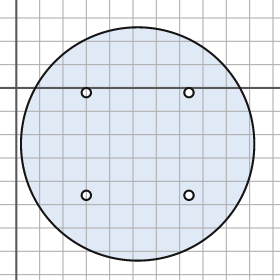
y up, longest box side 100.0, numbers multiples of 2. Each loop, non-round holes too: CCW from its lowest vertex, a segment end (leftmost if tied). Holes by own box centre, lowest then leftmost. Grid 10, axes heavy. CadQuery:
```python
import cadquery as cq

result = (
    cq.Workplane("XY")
    .moveTo(52.0, -24.0)
    .circle(50.0)
    .moveTo(30.0, -46.0)
    .circle(2.0)
    .moveTo(74.0, -46.0)
    .circle(2.0)
    .moveTo(30.0, -2.0)
    .circle(2.0)
    .moveTo(74.0, -2.0)
    .circle(2.0)
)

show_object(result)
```